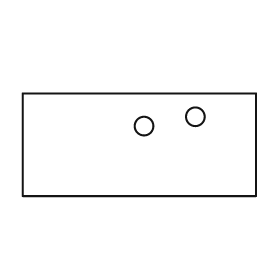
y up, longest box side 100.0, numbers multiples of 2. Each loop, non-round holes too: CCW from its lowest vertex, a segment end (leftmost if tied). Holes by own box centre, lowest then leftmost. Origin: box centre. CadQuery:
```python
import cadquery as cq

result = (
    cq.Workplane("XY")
    .moveTo(-50.0, -22.0)
    .lineTo(50.0, -22.0)
    .lineTo(50.0, 22.0)
    .lineTo(-50.0, 22.0)
    .close()
    .moveTo(2.0, 8.0)
    .circle(4.0)
    .moveTo(24.0, 12.0)
    .circle(4.0)
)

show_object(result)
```